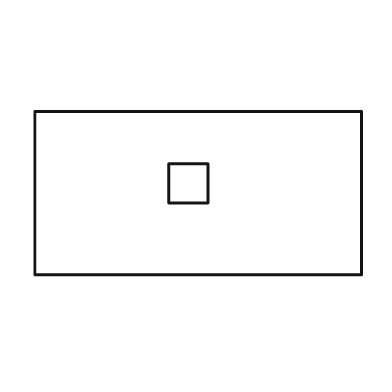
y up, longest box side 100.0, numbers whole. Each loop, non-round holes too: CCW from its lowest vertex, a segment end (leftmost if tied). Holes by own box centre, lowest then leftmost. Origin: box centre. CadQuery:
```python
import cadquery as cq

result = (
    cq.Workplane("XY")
    .moveTo(-50.0, -25.0)
    .lineTo(50.0, -25.0)
    .lineTo(50.0, 25.0)
    .lineTo(-50.0, 25.0)
    .close()
    .moveTo(-9.0, -3.0)
    .lineTo(3.0, -3.0)
    .lineTo(3.0, 9.0)
    .lineTo(-9.0, 9.0)
    .close()
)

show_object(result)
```